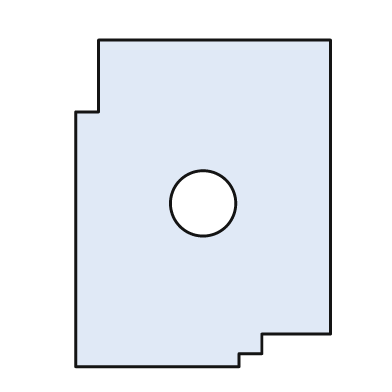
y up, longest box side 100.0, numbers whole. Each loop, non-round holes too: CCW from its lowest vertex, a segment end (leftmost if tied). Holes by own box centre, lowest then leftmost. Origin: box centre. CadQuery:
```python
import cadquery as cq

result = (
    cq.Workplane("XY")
    .moveTo(-39.0, -50.0)
    .lineTo(11.0, -50.0)
    .lineTo(11.0, -46.0)
    .lineTo(18.0, -46.0)
    .lineTo(18.0, -40.0)
    .lineTo(39.0, -40.0)
    .lineTo(39.0, 50.0)
    .lineTo(-32.0, 50.0)
    .lineTo(-32.0, 28.0)
    .lineTo(-39.0, 28.0)
    .close()
    .moveTo(0.0, 0.0)
    .circle(10.0)
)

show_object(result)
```